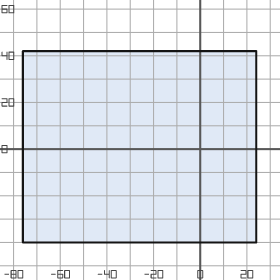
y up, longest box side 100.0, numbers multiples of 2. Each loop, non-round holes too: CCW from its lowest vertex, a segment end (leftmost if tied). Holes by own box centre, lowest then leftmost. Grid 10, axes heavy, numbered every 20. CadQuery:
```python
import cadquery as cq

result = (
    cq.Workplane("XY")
    .moveTo(-76.0, -40.0)
    .lineTo(24.0, -40.0)
    .lineTo(24.0, 42.0)
    .lineTo(-76.0, 42.0)
    .close()
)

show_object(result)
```